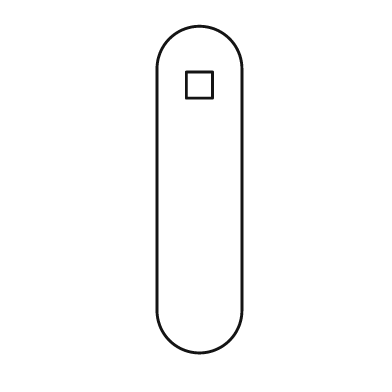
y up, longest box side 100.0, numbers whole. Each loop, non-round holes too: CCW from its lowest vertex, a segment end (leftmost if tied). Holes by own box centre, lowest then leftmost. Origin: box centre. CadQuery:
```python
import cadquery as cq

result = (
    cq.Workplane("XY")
    .moveTo(-13.0, -37.0)
    .threePointArc((0.0, -50.0), (13.0, -37.0))
    .lineTo(13.0, 37.0)
    .threePointArc((0.0, 50.0), (-13.0, 37.0))
    .close()
    .moveTo(-4.0, 28.0)
    .lineTo(4.0, 28.0)
    .lineTo(4.0, 36.0)
    .lineTo(-4.0, 36.0)
    .close()
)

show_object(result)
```